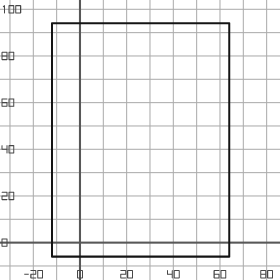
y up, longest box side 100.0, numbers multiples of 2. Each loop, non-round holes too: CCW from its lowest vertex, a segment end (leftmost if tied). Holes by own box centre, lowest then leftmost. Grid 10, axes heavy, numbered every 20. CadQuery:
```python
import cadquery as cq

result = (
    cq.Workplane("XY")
    .moveTo(-12.0, -6.0)
    .lineTo(64.0, -6.0)
    .lineTo(64.0, 94.0)
    .lineTo(-12.0, 94.0)
    .close()
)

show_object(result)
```